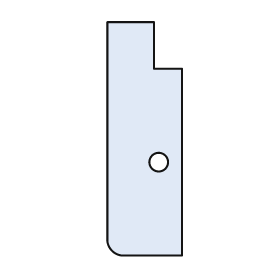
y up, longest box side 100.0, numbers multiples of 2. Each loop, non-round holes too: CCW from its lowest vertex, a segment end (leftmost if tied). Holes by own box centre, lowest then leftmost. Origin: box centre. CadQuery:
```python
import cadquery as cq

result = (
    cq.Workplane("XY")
    .moveTo(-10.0, -50.0)
    .lineTo(16.0, -50.0)
    .lineTo(16.0, 30.0)
    .lineTo(4.0, 30.0)
    .lineTo(4.0, 50.0)
    .lineTo(-16.0, 50.0)
    .lineTo(-16.0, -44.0)
    .threePointArc((-14.0, -48.0), (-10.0, -50.0))
    .close()
    .moveTo(6.0, -10.0)
    .circle(4.0)
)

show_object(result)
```